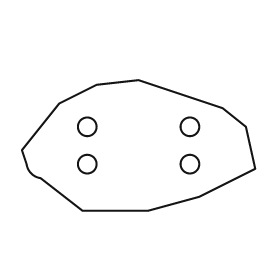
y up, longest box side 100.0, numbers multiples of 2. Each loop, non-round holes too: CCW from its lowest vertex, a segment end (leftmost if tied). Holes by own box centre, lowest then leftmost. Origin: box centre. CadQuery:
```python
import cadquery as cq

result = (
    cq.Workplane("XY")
    .moveTo(-24.0, -28.0)
    .lineTo(4.0, -28.0)
    .lineTo(26.0, -22.0)
    .lineTo(50.0, -10.0)
    .lineTo(46.0, 8.0)
    .lineTo(36.0, 16.0)
    .lineTo(0.0, 28.0)
    .lineTo(-18.0, 26.0)
    .lineTo(-34.0, 18.0)
    .lineTo(-50.0, -2.0)
    .lineTo(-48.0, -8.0)
    .threePointArc((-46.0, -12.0), (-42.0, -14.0))
    .close()
    .moveTo(-22.0, -8.0)
    .circle(4.0)
    .moveTo(22.0, -8.0)
    .circle(4.0)
    .moveTo(-22.0, 8.0)
    .circle(4.0)
    .moveTo(22.0, 8.0)
    .circle(4.0)
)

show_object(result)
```